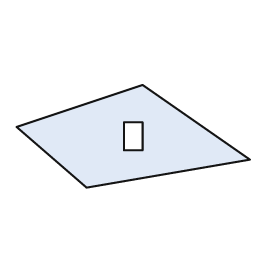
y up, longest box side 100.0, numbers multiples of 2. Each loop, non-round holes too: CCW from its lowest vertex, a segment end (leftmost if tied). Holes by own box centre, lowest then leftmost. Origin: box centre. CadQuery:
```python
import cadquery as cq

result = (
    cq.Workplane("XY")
    .moveTo(-20.0, -22.0)
    .lineTo(50.0, -10.0)
    .lineTo(4.0, 22.0)
    .lineTo(-50.0, 4.0)
    .close()
    .moveTo(-4.0, -6.0)
    .lineTo(4.0, -6.0)
    .lineTo(4.0, 6.0)
    .lineTo(-4.0, 6.0)
    .close()
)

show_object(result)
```